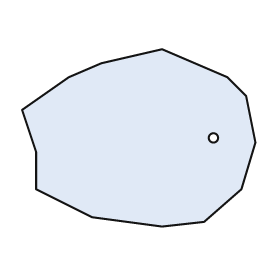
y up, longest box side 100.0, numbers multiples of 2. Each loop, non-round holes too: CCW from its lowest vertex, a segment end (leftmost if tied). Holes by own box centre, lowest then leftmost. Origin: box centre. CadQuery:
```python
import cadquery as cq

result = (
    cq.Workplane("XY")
    .moveTo(10.0, -38.0)
    .lineTo(28.0, -36.0)
    .lineTo(44.0, -22.0)
    .lineTo(50.0, -2.0)
    .lineTo(46.0, 18.0)
    .lineTo(38.0, 26.0)
    .lineTo(10.0, 38.0)
    .lineTo(-16.0, 32.0)
    .lineTo(-30.0, 26.0)
    .lineTo(-50.0, 12.0)
    .lineTo(-44.0, -6.0)
    .lineTo(-44.0, -22.0)
    .lineTo(-20.0, -34.0)
    .close()
    .moveTo(32.0, 0.0)
    .circle(2.0)
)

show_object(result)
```